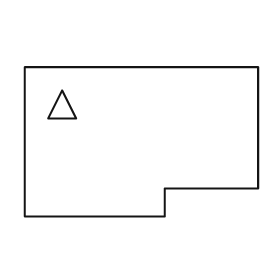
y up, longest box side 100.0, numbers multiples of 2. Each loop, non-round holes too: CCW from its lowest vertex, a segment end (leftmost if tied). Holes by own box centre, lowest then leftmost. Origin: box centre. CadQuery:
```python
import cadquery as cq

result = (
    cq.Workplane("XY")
    .moveTo(-50.0, -32.0)
    .lineTo(10.0, -32.0)
    .lineTo(10.0, -20.0)
    .lineTo(50.0, -20.0)
    .lineTo(50.0, 32.0)
    .lineTo(-50.0, 32.0)
    .close()
    .moveTo(-40.0, 10.0)
    .lineTo(-28.0, 10.0)
    .lineTo(-34.0, 22.0)
    .close()
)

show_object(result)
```